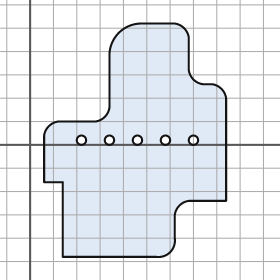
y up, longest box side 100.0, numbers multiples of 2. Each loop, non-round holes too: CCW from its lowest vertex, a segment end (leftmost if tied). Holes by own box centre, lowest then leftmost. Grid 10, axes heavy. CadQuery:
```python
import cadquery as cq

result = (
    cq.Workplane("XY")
    .moveTo(14.0, -48.0)
    .lineTo(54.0, -48.0)
    .threePointArc((60.0, -46.0), (62.0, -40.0))
    .lineTo(62.0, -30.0)
    .threePointArc((64.0, -26.0), (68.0, -24.0))
    .lineTo(84.0, -24.0)
    .lineTo(84.0, 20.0)
    .threePointArc((82.0, 24.0), (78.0, 26.0))
    .lineTo(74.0, 26.0)
    .threePointArc((70.0, 28.0), (68.0, 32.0))
    .lineTo(68.0, 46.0)
    .threePointArc((66.0, 50.0), (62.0, 52.0))
    .lineTo(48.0, 52.0)
    .threePointArc((38.0, 48.0), (34.0, 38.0))
    .lineTo(34.0, 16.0)
    .threePointArc((32.0, 12.0), (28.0, 10.0))
    .lineTo(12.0, 10.0)
    .threePointArc((8.0, 8.0), (6.0, 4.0))
    .lineTo(6.0, -16.0)
    .lineTo(14.0, -16.0)
    .close()
    .moveTo(22.0, 2.0)
    .circle(2.0)
    .moveTo(34.0, 2.0)
    .circle(2.0)
    .moveTo(46.0, 2.0)
    .circle(2.0)
    .moveTo(58.0, 2.0)
    .circle(2.0)
    .moveTo(70.0, 2.0)
    .circle(2.0)
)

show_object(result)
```